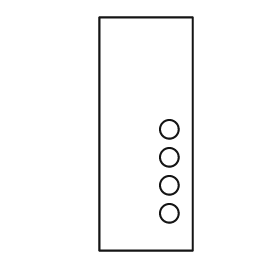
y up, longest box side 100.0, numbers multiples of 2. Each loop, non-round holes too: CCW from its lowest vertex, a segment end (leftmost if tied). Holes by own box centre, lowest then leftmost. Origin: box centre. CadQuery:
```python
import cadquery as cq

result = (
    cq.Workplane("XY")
    .moveTo(-20.0, -50.0)
    .lineTo(20.0, -50.0)
    .lineTo(20.0, 50.0)
    .lineTo(-20.0, 50.0)
    .close()
    .moveTo(10.0, -34.0)
    .circle(4.0)
    .moveTo(10.0, -22.0)
    .circle(4.0)
    .moveTo(10.0, -10.0)
    .circle(4.0)
    .moveTo(10.0, 2.0)
    .circle(4.0)
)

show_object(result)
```